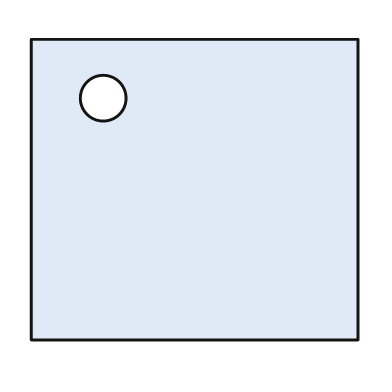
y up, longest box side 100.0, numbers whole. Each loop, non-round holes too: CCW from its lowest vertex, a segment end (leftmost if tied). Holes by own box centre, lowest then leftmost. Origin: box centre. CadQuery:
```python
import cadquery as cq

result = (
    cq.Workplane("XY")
    .moveTo(-50.0, -46.0)
    .lineTo(50.0, -46.0)
    .lineTo(50.0, 46.0)
    .lineTo(-50.0, 46.0)
    .close()
    .moveTo(-28.0, 28.0)
    .circle(7.0)
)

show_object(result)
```